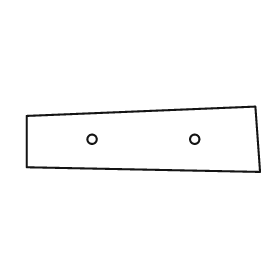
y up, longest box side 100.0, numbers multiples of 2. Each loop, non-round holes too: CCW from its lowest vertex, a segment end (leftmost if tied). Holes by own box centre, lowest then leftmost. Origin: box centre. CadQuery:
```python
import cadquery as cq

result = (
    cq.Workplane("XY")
    .moveTo(50.0, -14.0)
    .lineTo(48.0, 14.0)
    .lineTo(-50.0, 10.0)
    .lineTo(-50.0, -12.0)
    .close()
    .moveTo(-22.0, 0.0)
    .circle(2.0)
    .moveTo(22.0, 0.0)
    .circle(2.0)
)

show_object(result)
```